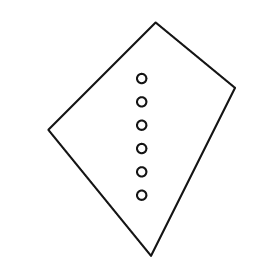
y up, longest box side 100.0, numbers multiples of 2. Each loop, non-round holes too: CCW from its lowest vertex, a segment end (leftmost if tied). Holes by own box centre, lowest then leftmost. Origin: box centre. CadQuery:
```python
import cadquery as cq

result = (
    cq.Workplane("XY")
    .moveTo(4.0, -50.0)
    .lineTo(40.0, 22.0)
    .lineTo(6.0, 50.0)
    .lineTo(-40.0, 4.0)
    .close()
    .moveTo(0.0, -24.0)
    .circle(2.0)
    .moveTo(0.0, -14.0)
    .circle(2.0)
    .moveTo(0.0, -4.0)
    .circle(2.0)
    .moveTo(0.0, 6.0)
    .circle(2.0)
    .moveTo(0.0, 16.0)
    .circle(2.0)
    .moveTo(0.0, 26.0)
    .circle(2.0)
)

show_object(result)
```